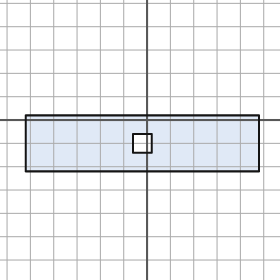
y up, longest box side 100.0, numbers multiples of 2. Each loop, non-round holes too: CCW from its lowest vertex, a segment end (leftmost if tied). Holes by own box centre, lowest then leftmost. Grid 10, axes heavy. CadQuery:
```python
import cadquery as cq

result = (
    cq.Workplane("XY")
    .moveTo(-52.0, -22.0)
    .lineTo(48.0, -22.0)
    .lineTo(48.0, 2.0)
    .lineTo(-52.0, 2.0)
    .close()
    .moveTo(-6.0, -14.0)
    .lineTo(2.0, -14.0)
    .lineTo(2.0, -6.0)
    .lineTo(-6.0, -6.0)
    .close()
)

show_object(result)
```